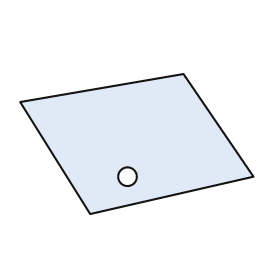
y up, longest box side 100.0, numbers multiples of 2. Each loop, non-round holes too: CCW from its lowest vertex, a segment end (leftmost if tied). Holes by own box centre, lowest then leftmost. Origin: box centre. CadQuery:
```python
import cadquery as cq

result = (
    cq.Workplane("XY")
    .moveTo(-20.0, -30.0)
    .lineTo(50.0, -14.0)
    .lineTo(20.0, 30.0)
    .lineTo(-50.0, 18.0)
    .close()
    .moveTo(-4.0, -14.0)
    .circle(4.0)
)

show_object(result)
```